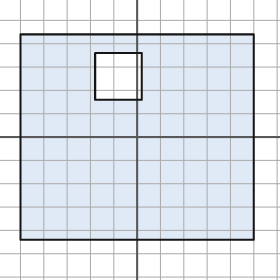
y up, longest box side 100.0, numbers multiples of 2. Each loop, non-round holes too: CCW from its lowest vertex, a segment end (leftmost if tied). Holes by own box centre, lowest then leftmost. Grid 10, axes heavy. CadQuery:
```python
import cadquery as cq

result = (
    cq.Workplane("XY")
    .moveTo(-50.0, -44.0)
    .lineTo(50.0, -44.0)
    .lineTo(50.0, 44.0)
    .lineTo(-50.0, 44.0)
    .close()
    .moveTo(-18.0, 16.0)
    .lineTo(2.0, 16.0)
    .lineTo(2.0, 36.0)
    .lineTo(-18.0, 36.0)
    .close()
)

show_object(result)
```